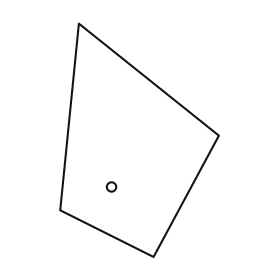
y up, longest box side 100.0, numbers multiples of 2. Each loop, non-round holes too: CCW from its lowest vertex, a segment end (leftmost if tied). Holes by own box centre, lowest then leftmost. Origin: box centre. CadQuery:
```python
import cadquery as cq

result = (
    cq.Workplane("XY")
    .moveTo(6.0, -50.0)
    .lineTo(34.0, 2.0)
    .lineTo(-26.0, 50.0)
    .lineTo(-34.0, -30.0)
    .close()
    .moveTo(-12.0, -20.0)
    .circle(2.0)
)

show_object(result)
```